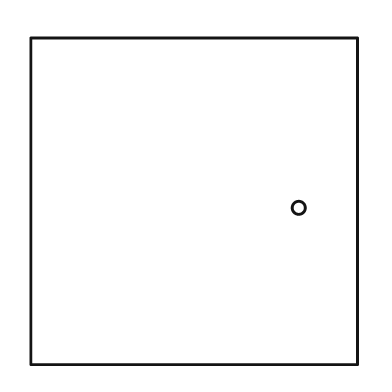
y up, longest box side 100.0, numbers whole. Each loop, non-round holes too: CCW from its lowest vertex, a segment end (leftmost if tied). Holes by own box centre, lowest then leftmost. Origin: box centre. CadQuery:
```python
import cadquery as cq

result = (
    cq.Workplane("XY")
    .moveTo(-50.0, -50.0)
    .lineTo(50.0, -50.0)
    .lineTo(50.0, 50.0)
    .lineTo(-50.0, 50.0)
    .close()
    .moveTo(32.0, -2.0)
    .circle(2.0)
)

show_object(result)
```